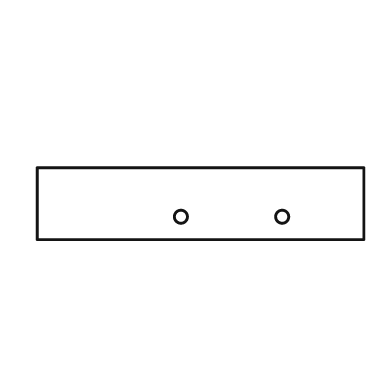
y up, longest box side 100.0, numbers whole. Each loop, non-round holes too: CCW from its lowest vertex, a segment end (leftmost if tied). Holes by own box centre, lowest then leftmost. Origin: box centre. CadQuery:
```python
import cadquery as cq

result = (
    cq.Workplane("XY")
    .moveTo(-50.0, -11.0)
    .lineTo(50.0, -11.0)
    .lineTo(50.0, 11.0)
    .lineTo(-50.0, 11.0)
    .close()
    .moveTo(-6.0, -4.0)
    .circle(2.0)
    .moveTo(25.0, -4.0)
    .circle(2.0)
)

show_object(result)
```